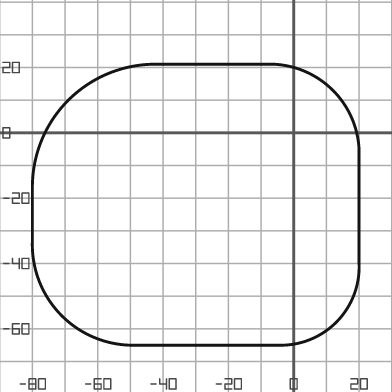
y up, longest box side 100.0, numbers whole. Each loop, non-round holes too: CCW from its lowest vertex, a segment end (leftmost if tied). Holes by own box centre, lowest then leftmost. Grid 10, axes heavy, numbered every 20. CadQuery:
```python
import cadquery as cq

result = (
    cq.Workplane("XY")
    .moveTo(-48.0, -65.0)
    .lineTo(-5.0, -65.0)
    .threePointArc((13.0, -58.0), (20.0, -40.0))
    .lineTo(20.0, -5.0)
    .threePointArc((12.0, 13.0), (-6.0, 21.0))
    .lineTo(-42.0, 21.0)
    .threePointArc((-69.0, 10.0), (-80.0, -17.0))
    .lineTo(-80.0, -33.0)
    .threePointArc((-71.0, -56.0), (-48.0, -65.0))
    .close()
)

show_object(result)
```